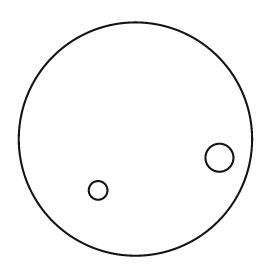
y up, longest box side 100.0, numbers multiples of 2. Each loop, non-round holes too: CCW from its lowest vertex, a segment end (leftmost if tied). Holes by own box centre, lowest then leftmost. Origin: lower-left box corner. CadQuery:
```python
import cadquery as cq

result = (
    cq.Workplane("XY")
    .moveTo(50.0, 50.0)
    .circle(50.0)
    .moveTo(34.0, 28.0)
    .circle(4.0)
    .moveTo(86.0, 42.0)
    .circle(6.0)
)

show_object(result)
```